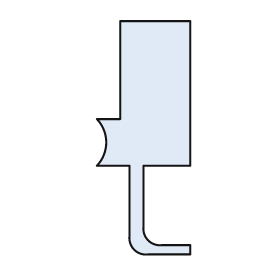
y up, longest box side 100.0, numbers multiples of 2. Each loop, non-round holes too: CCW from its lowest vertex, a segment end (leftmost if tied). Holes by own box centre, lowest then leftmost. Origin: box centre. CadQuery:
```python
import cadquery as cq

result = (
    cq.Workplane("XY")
    .moveTo(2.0, -50.0)
    .lineTo(20.0, -50.0)
    .lineTo(20.0, -46.0)
    .lineTo(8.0, -46.0)
    .threePointArc((2.0, -44.0), (0.0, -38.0))
    .lineTo(0.0, -12.0)
    .lineTo(20.0, -12.0)
    .lineTo(20.0, 50.0)
    .lineTo(-10.0, 50.0)
    .lineTo(-10.0, 8.0)
    .lineTo(-20.0, 8.0)
    .threePointArc((-16.0, -2.0), (-20.0, -12.0))
    .lineTo(-6.0, -12.0)
    .lineTo(-6.0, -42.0)
    .threePointArc((-4.0, -48.0), (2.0, -50.0))
    .close()
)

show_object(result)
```